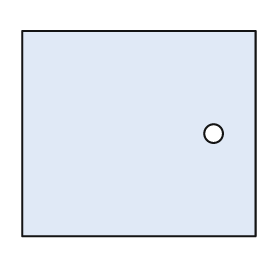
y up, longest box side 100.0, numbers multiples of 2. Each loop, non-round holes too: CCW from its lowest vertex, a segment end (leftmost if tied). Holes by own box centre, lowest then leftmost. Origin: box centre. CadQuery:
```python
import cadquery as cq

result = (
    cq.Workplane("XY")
    .moveTo(-50.0, -44.0)
    .lineTo(50.0, -44.0)
    .lineTo(50.0, 44.0)
    .lineTo(-50.0, 44.0)
    .close()
    .moveTo(32.0, 0.0)
    .circle(4.0)
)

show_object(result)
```